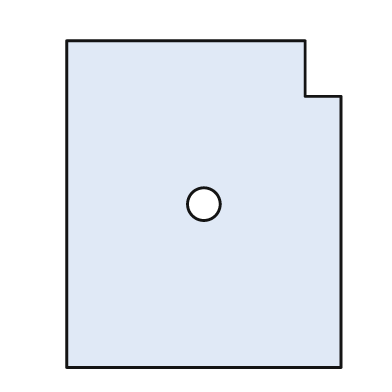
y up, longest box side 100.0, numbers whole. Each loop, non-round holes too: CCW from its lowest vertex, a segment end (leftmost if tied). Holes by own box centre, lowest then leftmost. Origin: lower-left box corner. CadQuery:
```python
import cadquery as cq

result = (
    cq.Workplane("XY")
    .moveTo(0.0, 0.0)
    .lineTo(84.0, 0.0)
    .lineTo(84.0, 83.0)
    .lineTo(73.0, 83.0)
    .lineTo(73.0, 100.0)
    .lineTo(0.0, 100.0)
    .close()
    .moveTo(42.0, 50.0)
    .circle(5.0)
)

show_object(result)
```